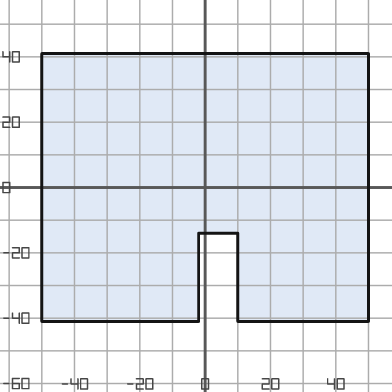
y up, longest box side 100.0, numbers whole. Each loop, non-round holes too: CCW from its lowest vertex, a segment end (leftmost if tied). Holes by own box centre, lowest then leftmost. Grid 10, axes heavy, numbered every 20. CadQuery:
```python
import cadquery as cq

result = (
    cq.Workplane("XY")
    .moveTo(-50.0, -41.0)
    .lineTo(-2.0, -41.0)
    .lineTo(-2.0, -14.0)
    .lineTo(10.0, -14.0)
    .lineTo(10.0, -41.0)
    .lineTo(50.0, -41.0)
    .lineTo(50.0, 41.0)
    .lineTo(-50.0, 41.0)
    .close()
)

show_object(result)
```